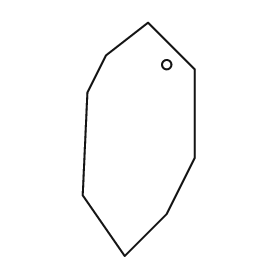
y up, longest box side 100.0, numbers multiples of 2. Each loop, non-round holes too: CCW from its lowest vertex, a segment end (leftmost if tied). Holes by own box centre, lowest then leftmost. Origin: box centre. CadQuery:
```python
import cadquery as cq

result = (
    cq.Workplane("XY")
    .moveTo(-6.0, -50.0)
    .lineTo(12.0, -32.0)
    .lineTo(24.0, -8.0)
    .lineTo(24.0, 30.0)
    .lineTo(4.0, 50.0)
    .lineTo(-14.0, 36.0)
    .lineTo(-22.0, 20.0)
    .lineTo(-24.0, -24.0)
    .close()
    .moveTo(12.0, 32.0)
    .circle(2.0)
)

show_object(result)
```